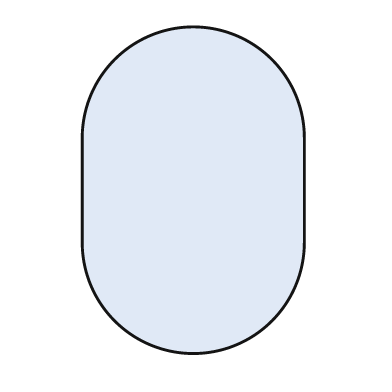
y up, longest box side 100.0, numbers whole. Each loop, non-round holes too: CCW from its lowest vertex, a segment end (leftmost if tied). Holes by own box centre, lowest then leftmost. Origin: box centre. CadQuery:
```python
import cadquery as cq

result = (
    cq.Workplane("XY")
    .moveTo(-34.0, -16.0)
    .threePointArc((0.0, -50.0), (34.0, -16.0))
    .lineTo(34.0, 16.0)
    .threePointArc((0.0, 50.0), (-34.0, 16.0))
    .close()
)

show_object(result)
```